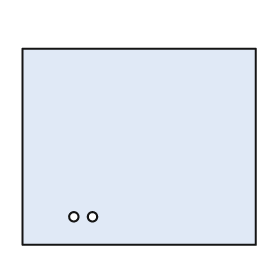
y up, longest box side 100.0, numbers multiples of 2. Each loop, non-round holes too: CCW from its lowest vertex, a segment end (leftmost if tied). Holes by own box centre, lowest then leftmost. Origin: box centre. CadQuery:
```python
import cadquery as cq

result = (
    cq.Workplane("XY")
    .moveTo(-50.0, -42.0)
    .lineTo(50.0, -42.0)
    .lineTo(50.0, 42.0)
    .lineTo(-50.0, 42.0)
    .close()
    .moveTo(-28.0, -30.0)
    .circle(2.0)
    .moveTo(-20.0, -30.0)
    .circle(2.0)
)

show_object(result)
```